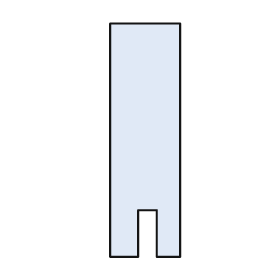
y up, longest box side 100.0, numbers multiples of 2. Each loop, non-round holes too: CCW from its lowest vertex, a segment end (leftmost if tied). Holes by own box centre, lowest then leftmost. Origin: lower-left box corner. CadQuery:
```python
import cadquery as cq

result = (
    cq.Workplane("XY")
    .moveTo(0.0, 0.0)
    .lineTo(12.0, 0.0)
    .lineTo(12.0, 20.0)
    .lineTo(20.0, 20.0)
    .lineTo(20.0, 0.0)
    .lineTo(30.0, 0.0)
    .lineTo(30.0, 100.0)
    .lineTo(0.0, 100.0)
    .close()
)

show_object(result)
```